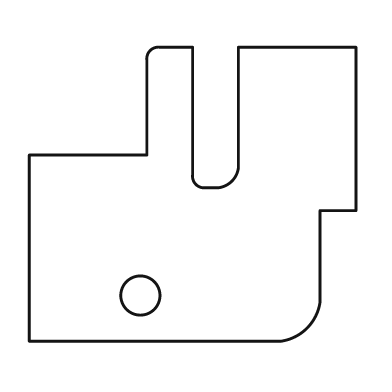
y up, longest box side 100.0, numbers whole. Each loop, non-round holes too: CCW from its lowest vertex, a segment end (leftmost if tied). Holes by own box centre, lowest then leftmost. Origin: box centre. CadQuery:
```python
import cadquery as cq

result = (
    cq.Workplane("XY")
    .moveTo(-50.0, -45.0)
    .lineTo(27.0, -45.0)
    .threePointArc((35.0, -41.0), (39.0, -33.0))
    .lineTo(39.0, -5.0)
    .lineTo(50.0, -5.0)
    .lineTo(50.0, 45.0)
    .lineTo(14.0, 45.0)
    .lineTo(14.0, 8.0)
    .threePointArc((12.0, 4.0), (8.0, 2.0))
    .lineTo(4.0, 2.0)
    .threePointArc((1.0, 3.0), (0.0, 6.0))
    .lineTo(0.0, 45.0)
    .lineTo(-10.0, 45.0)
    .threePointArc((-13.0, 44.0), (-14.0, 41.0))
    .lineTo(-14.0, 12.0)
    .lineTo(-50.0, 12.0)
    .close()
    .moveTo(-16.0, -31.0)
    .circle(6.0)
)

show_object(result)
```